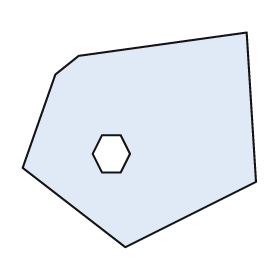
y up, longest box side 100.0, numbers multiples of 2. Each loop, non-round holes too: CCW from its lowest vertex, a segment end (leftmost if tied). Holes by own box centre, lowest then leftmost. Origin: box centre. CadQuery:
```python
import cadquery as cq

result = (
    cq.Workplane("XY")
    .moveTo(-6.0, -46.0)
    .lineTo(50.0, -18.0)
    .lineTo(46.0, 46.0)
    .lineTo(-26.0, 36.0)
    .lineTo(-36.0, 28.0)
    .lineTo(-50.0, -12.0)
    .close()
    .moveTo(-16.0, -14.0)
    .lineTo(-8.0, -14.0)
    .lineTo(-4.0, -6.0)
    .lineTo(-8.0, 2.0)
    .lineTo(-16.0, 2.0)
    .lineTo(-20.0, -6.0)
    .close()
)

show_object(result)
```